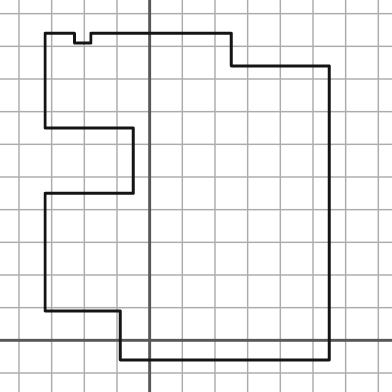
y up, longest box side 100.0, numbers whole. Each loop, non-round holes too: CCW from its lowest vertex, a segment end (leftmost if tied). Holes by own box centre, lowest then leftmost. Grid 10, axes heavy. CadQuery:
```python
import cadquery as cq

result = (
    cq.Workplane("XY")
    .moveTo(-9.0, -6.0)
    .lineTo(55.0, -6.0)
    .lineTo(55.0, 84.0)
    .lineTo(25.0, 84.0)
    .lineTo(25.0, 94.0)
    .lineTo(-18.0, 94.0)
    .lineTo(-18.0, 91.0)
    .lineTo(-23.0, 91.0)
    .lineTo(-23.0, 94.0)
    .lineTo(-32.0, 94.0)
    .lineTo(-32.0, 65.0)
    .lineTo(-5.0, 65.0)
    .lineTo(-5.0, 45.0)
    .lineTo(-32.0, 45.0)
    .lineTo(-32.0, 9.0)
    .lineTo(-9.0, 9.0)
    .close()
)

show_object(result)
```